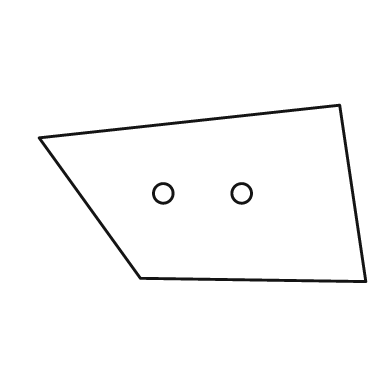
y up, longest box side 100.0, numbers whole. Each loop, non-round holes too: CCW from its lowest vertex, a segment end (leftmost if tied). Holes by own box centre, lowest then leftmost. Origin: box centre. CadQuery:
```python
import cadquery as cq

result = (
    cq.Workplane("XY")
    .moveTo(50.0, -27.0)
    .lineTo(42.0, 27.0)
    .lineTo(-50.0, 17.0)
    .lineTo(-19.0, -26.0)
    .close()
    .moveTo(-12.0, 0.0)
    .circle(3.0)
    .moveTo(12.0, 0.0)
    .circle(3.0)
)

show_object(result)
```